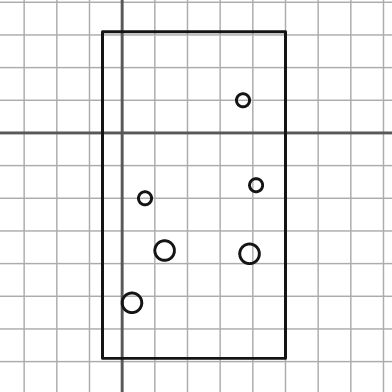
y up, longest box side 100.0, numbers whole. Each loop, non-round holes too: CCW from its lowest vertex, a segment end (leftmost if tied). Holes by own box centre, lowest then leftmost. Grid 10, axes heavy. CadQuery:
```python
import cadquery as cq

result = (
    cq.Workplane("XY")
    .moveTo(-6.0, -69.0)
    .lineTo(50.0, -69.0)
    .lineTo(50.0, 31.0)
    .lineTo(-6.0, 31.0)
    .close()
    .moveTo(3.0, -52.0)
    .circle(3.0)
    .moveTo(39.0, -37.0)
    .circle(3.0)
    .moveTo(13.0, -36.0)
    .circle(3.0)
    .moveTo(7.0, -20.0)
    .circle(2.0)
    .moveTo(41.0, -16.0)
    .circle(2.0)
    .moveTo(37.0, 10.0)
    .circle(2.0)
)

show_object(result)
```